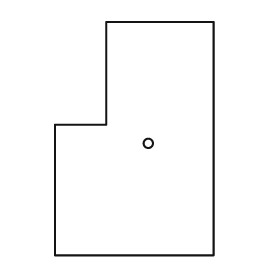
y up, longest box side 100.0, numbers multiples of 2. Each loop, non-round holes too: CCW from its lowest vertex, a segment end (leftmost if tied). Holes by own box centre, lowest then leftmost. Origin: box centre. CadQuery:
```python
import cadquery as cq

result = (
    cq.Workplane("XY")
    .moveTo(-34.0, -50.0)
    .lineTo(34.0, -50.0)
    .lineTo(34.0, 50.0)
    .lineTo(-12.0, 50.0)
    .lineTo(-12.0, 6.0)
    .lineTo(-34.0, 6.0)
    .close()
    .moveTo(6.0, -2.0)
    .circle(2.0)
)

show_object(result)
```